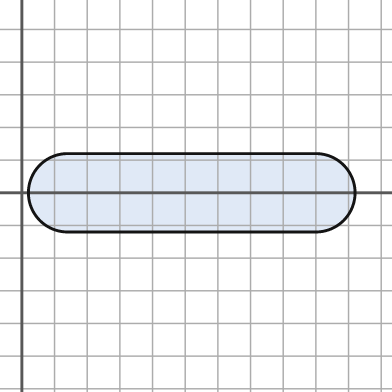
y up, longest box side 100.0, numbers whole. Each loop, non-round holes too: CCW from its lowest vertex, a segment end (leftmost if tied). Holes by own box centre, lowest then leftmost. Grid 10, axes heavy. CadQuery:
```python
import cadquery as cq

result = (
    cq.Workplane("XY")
    .moveTo(14.0, -12.0)
    .lineTo(90.0, -12.0)
    .threePointArc((102.0, 0.0), (90.0, 12.0))
    .lineTo(14.0, 12.0)
    .threePointArc((2.0, 0.0), (14.0, -12.0))
    .close()
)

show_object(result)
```